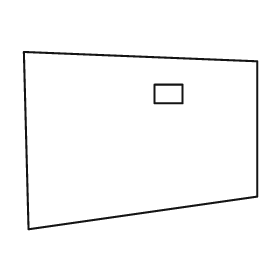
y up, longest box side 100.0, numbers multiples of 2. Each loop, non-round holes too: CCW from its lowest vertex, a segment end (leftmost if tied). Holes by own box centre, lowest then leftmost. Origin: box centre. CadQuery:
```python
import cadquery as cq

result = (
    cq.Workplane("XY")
    .moveTo(-48.0, -38.0)
    .lineTo(50.0, -24.0)
    .lineTo(50.0, 34.0)
    .lineTo(-50.0, 38.0)
    .close()
    .moveTo(6.0, 16.0)
    .lineTo(18.0, 16.0)
    .lineTo(18.0, 24.0)
    .lineTo(6.0, 24.0)
    .close()
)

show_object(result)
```